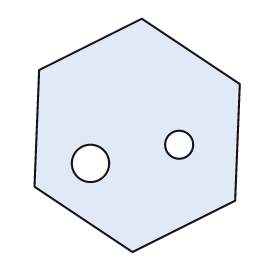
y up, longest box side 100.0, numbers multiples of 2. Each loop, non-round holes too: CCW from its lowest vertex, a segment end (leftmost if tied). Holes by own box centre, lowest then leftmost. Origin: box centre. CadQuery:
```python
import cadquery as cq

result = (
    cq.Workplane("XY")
    .moveTo(-2.0, -50.0)
    .lineTo(42.0, -28.0)
    .lineTo(44.0, 22.0)
    .lineTo(2.0, 50.0)
    .lineTo(-42.0, 28.0)
    .lineTo(-44.0, -22.0)
    .close()
    .moveTo(-20.0, -12.0)
    .circle(8.0)
    .moveTo(18.0, -4.0)
    .circle(6.0)
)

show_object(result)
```